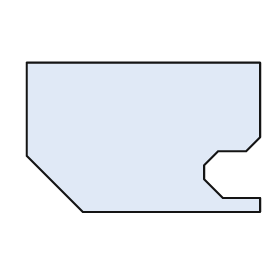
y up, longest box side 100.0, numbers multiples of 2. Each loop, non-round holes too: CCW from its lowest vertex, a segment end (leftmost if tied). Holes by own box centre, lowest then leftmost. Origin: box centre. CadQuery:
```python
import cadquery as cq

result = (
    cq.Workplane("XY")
    .moveTo(-26.0, -32.0)
    .lineTo(50.0, -32.0)
    .lineTo(50.0, -26.0)
    .lineTo(34.0, -26.0)
    .lineTo(26.0, -18.0)
    .lineTo(26.0, -12.0)
    .lineTo(32.0, -6.0)
    .lineTo(44.0, -6.0)
    .lineTo(50.0, 0.0)
    .lineTo(50.0, 32.0)
    .lineTo(-50.0, 32.0)
    .lineTo(-50.0, -8.0)
    .close()
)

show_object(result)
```